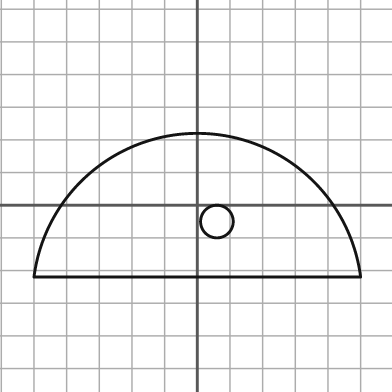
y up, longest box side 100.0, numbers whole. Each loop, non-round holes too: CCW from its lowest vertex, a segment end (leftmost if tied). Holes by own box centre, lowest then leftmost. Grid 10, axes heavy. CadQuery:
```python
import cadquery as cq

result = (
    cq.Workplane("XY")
    .moveTo(-50.0, -22.0)
    .lineTo(50.0, -22.0)
    .threePointArc((0.0, 22.0), (-50.0, -22.0))
    .close()
    .moveTo(6.0, -5.0)
    .circle(5.0)
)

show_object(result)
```